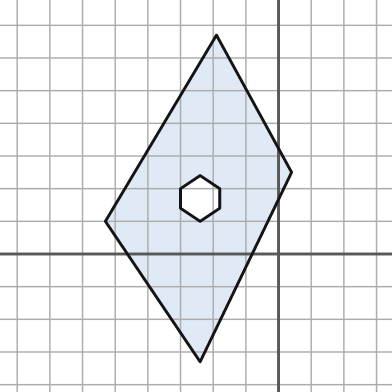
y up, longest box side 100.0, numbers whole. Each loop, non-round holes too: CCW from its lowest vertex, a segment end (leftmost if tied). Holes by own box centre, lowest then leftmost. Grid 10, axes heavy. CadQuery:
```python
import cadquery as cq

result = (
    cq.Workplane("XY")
    .moveTo(-24.0, -33.0)
    .lineTo(4.0, 25.0)
    .lineTo(-19.0, 67.0)
    .lineTo(-53.0, 10.0)
    .close()
    .moveTo(-24.0, 10.0)
    .lineTo(-18.0, 14.0)
    .lineTo(-18.0, 20.0)
    .lineTo(-24.0, 24.0)
    .lineTo(-30.0, 20.0)
    .lineTo(-30.0, 14.0)
    .close()
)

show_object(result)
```